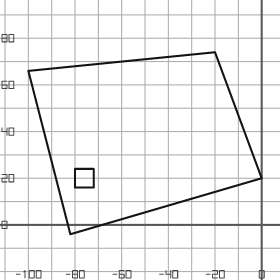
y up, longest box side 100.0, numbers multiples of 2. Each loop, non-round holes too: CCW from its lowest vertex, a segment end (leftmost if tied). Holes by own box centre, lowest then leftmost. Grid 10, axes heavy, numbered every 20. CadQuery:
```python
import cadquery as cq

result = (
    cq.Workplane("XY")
    .moveTo(-82.0, -4.0)
    .lineTo(0.0, 20.0)
    .lineTo(-20.0, 74.0)
    .lineTo(-100.0, 66.0)
    .close()
    .moveTo(-80.0, 16.0)
    .lineTo(-72.0, 16.0)
    .lineTo(-72.0, 24.0)
    .lineTo(-80.0, 24.0)
    .close()
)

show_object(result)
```